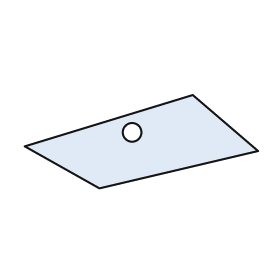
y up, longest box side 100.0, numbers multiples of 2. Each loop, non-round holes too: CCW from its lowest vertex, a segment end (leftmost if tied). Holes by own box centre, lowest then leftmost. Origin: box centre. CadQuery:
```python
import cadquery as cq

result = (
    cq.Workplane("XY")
    .moveTo(-18.0, -20.0)
    .lineTo(50.0, -4.0)
    .lineTo(22.0, 20.0)
    .lineTo(-50.0, -2.0)
    .close()
    .moveTo(-4.0, 4.0)
    .circle(4.0)
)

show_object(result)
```